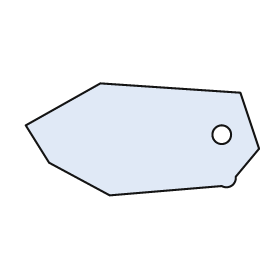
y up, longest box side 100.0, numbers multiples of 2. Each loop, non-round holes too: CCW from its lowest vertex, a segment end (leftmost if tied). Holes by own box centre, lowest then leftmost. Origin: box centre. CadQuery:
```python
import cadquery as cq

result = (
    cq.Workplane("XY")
    .moveTo(-14.0, -24.0)
    .lineTo(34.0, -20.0)
    .threePointArc((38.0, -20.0), (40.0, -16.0))
    .lineTo(50.0, -4.0)
    .lineTo(42.0, 20.0)
    .lineTo(-18.0, 24.0)
    .lineTo(-50.0, 6.0)
    .lineTo(-40.0, -10.0)
    .close()
    .moveTo(34.0, 2.0)
    .circle(4.0)
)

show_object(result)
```